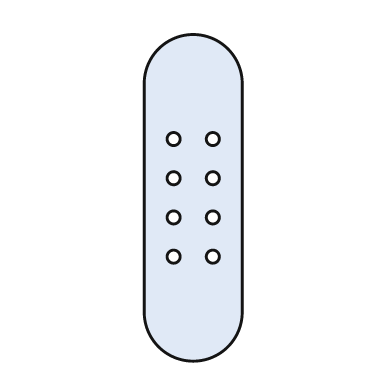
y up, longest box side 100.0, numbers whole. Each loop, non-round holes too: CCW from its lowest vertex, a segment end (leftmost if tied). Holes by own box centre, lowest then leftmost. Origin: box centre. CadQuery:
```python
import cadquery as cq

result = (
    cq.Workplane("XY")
    .moveTo(-15.0, -35.0)
    .threePointArc((0.0, -50.0), (15.0, -35.0))
    .lineTo(15.0, 35.0)
    .threePointArc((0.0, 50.0), (-15.0, 35.0))
    .close()
    .moveTo(-6.0, -18.0)
    .circle(2.0)
    .moveTo(6.0, -18.0)
    .circle(2.0)
    .moveTo(-6.0, -6.0)
    .circle(2.0)
    .moveTo(6.0, -6.0)
    .circle(2.0)
    .moveTo(-6.0, 6.0)
    .circle(2.0)
    .moveTo(6.0, 6.0)
    .circle(2.0)
    .moveTo(-6.0, 18.0)
    .circle(2.0)
    .moveTo(6.0, 18.0)
    .circle(2.0)
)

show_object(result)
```